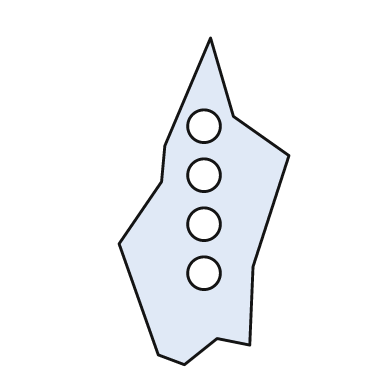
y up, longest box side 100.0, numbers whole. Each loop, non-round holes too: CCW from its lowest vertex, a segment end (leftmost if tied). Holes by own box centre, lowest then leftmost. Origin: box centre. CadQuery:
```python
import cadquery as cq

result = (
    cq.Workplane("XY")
    .moveTo(-6.0, -50.0)
    .lineTo(4.0, -42.0)
    .lineTo(14.0, -44.0)
    .lineTo(15.0, -20.0)
    .lineTo(26.0, 14.0)
    .lineTo(9.0, 26.0)
    .lineTo(2.0, 50.0)
    .lineTo(-12.0, 17.0)
    .lineTo(-13.0, 6.0)
    .lineTo(-26.0, -13.0)
    .lineTo(-14.0, -47.0)
    .close()
    .moveTo(0.0, -22.0)
    .circle(5.0)
    .moveTo(0.0, -7.0)
    .circle(5.0)
    .moveTo(0.0, 8.0)
    .circle(5.0)
    .moveTo(0.0, 23.0)
    .circle(5.0)
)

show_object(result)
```